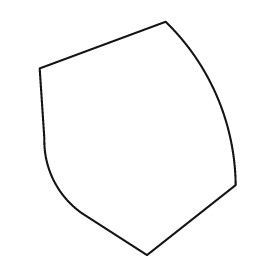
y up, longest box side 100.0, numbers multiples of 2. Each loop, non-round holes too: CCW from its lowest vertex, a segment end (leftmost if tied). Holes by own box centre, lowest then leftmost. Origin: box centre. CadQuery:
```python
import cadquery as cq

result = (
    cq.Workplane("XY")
    .moveTo(4.0, -50.0)
    .lineTo(42.0, -20.0)
    .threePointArc((34.0, 18.0), (12.0, 50.0))
    .lineTo(-42.0, 30.0)
    .lineTo(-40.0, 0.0)
    .threePointArc((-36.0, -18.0), (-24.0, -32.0))
    .close()
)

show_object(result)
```